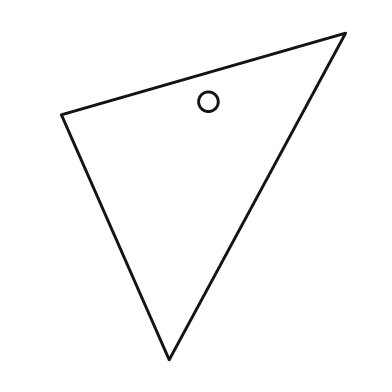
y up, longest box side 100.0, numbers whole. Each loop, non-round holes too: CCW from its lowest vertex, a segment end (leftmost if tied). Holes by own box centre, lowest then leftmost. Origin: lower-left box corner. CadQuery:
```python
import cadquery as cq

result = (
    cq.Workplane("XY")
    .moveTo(33.0, 0.0)
    .lineTo(87.0, 100.0)
    .lineTo(0.0, 75.0)
    .close()
    .moveTo(45.0, 79.0)
    .circle(3.0)
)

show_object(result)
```